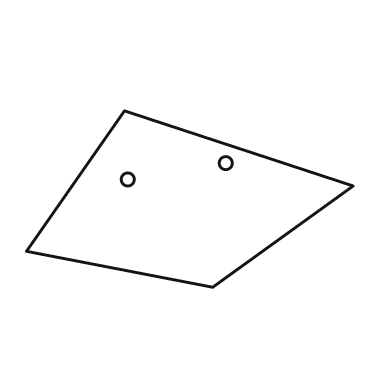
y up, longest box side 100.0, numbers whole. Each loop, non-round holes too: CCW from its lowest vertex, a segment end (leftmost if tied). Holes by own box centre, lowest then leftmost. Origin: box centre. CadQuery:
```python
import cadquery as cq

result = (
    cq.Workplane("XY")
    .moveTo(7.0, -27.0)
    .lineTo(50.0, 4.0)
    .lineTo(-20.0, 27.0)
    .lineTo(-50.0, -16.0)
    .close()
    .moveTo(-19.0, 6.0)
    .circle(2.0)
    .moveTo(11.0, 11.0)
    .circle(2.0)
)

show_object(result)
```